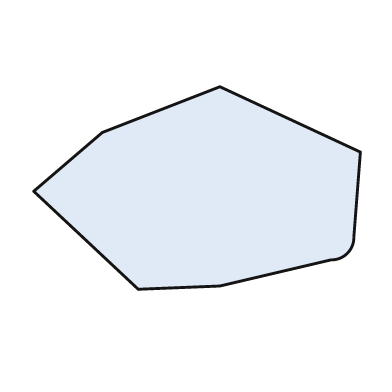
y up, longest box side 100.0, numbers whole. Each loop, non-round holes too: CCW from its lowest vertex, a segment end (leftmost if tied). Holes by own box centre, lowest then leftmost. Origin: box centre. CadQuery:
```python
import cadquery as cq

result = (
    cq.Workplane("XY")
    .moveTo(-18.0, -31.0)
    .lineTo(7.0, -30.0)
    .lineTo(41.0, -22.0)
    .threePointArc((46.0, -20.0), (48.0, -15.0))
    .lineTo(50.0, 11.0)
    .lineTo(7.0, 31.0)
    .lineTo(-29.0, 17.0)
    .lineTo(-50.0, -1.0)
    .close()
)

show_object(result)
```